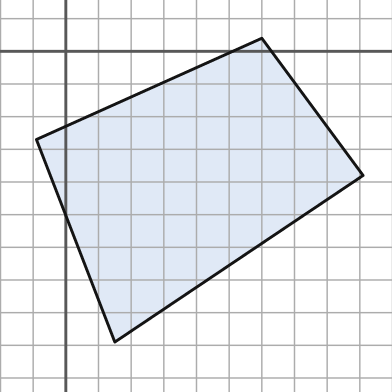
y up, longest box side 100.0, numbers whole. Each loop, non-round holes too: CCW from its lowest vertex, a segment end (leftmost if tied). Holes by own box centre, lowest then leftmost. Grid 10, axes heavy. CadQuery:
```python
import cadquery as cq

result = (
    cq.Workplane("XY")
    .moveTo(15.0, -89.0)
    .lineTo(91.0, -38.0)
    .lineTo(60.0, 4.0)
    .lineTo(-9.0, -27.0)
    .close()
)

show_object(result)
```